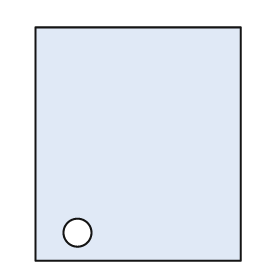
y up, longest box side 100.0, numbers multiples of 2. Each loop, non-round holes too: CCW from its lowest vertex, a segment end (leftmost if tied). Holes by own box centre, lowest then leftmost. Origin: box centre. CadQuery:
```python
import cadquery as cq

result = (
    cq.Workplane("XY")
    .moveTo(-44.0, -50.0)
    .lineTo(44.0, -50.0)
    .lineTo(44.0, 50.0)
    .lineTo(-44.0, 50.0)
    .close()
    .moveTo(-26.0, -38.0)
    .circle(6.0)
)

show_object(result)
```